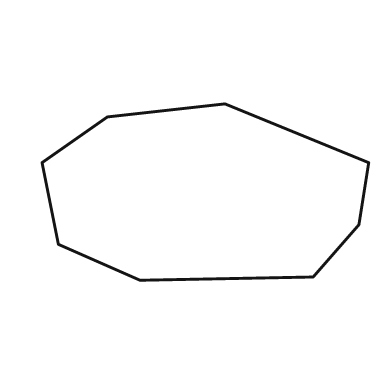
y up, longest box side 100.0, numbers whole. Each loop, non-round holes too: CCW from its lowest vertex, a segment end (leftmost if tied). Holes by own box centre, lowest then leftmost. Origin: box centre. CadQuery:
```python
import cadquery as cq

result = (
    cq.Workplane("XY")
    .moveTo(-20.0, -27.0)
    .lineTo(33.0, -26.0)
    .lineTo(47.0, -10.0)
    .lineTo(50.0, 9.0)
    .lineTo(6.0, 27.0)
    .lineTo(-30.0, 23.0)
    .lineTo(-50.0, 9.0)
    .lineTo(-45.0, -16.0)
    .close()
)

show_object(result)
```